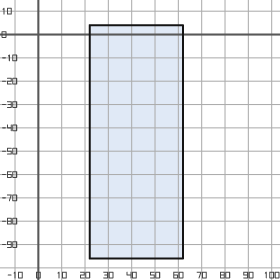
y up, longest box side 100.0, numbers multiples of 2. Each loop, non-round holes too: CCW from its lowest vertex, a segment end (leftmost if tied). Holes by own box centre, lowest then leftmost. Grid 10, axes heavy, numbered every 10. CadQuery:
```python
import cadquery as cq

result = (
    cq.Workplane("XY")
    .moveTo(22.0, -96.0)
    .lineTo(62.0, -96.0)
    .lineTo(62.0, 4.0)
    .lineTo(22.0, 4.0)
    .close()
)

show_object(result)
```